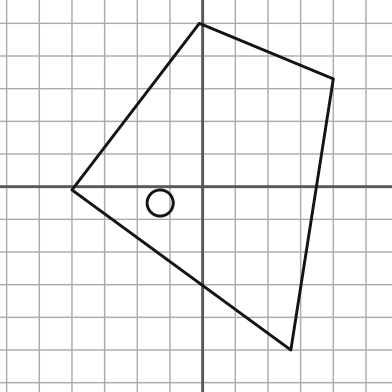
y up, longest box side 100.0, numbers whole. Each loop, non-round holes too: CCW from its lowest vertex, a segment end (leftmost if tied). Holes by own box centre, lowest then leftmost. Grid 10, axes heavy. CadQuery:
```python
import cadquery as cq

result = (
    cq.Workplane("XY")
    .moveTo(27.0, -50.0)
    .lineTo(40.0, 33.0)
    .lineTo(-1.0, 50.0)
    .lineTo(-40.0, -1.0)
    .close()
    .moveTo(-13.0, -5.0)
    .circle(4.0)
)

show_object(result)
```